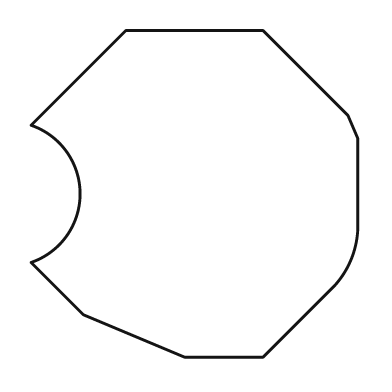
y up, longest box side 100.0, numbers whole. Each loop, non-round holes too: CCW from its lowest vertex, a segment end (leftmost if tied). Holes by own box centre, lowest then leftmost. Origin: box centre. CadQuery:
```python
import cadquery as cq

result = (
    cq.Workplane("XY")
    .moveTo(-3.0, -50.0)
    .lineTo(21.0, -50.0)
    .lineTo(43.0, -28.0)
    .threePointArc((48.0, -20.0), (50.0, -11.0))
    .lineTo(50.0, 17.0)
    .lineTo(47.0, 24.0)
    .lineTo(21.0, 50.0)
    .lineTo(-21.0, 50.0)
    .lineTo(-50.0, 21.0)
    .threePointArc((-35.0, 0.0), (-50.0, -21.0))
    .lineTo(-34.0, -37.0)
    .close()
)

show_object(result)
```